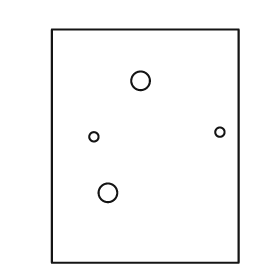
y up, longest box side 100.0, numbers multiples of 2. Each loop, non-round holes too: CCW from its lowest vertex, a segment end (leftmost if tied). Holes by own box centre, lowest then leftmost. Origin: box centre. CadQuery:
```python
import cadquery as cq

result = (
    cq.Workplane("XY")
    .moveTo(-40.0, -50.0)
    .lineTo(40.0, -50.0)
    .lineTo(40.0, 50.0)
    .lineTo(-40.0, 50.0)
    .close()
    .moveTo(-16.0, -20.0)
    .circle(4.0)
    .moveTo(-22.0, 4.0)
    .circle(2.0)
    .moveTo(32.0, 6.0)
    .circle(2.0)
    .moveTo(-2.0, 28.0)
    .circle(4.0)
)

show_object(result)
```